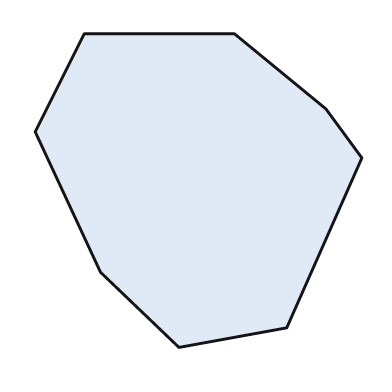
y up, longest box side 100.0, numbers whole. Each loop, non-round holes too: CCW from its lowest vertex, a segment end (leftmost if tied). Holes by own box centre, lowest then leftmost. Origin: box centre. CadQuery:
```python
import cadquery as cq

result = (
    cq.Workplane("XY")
    .moveTo(-6.0, -48.0)
    .lineTo(27.0, -42.0)
    .lineTo(50.0, 10.0)
    .lineTo(39.0, 25.0)
    .lineTo(11.0, 48.0)
    .lineTo(-35.0, 48.0)
    .lineTo(-50.0, 18.0)
    .lineTo(-30.0, -25.0)
    .close()
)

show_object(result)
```